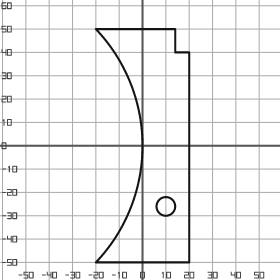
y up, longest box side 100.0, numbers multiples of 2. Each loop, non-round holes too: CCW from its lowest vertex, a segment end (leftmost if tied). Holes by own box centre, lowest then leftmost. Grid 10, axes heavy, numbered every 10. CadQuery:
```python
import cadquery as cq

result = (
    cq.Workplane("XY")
    .moveTo(-20.0, -50.0)
    .lineTo(20.0, -50.0)
    .lineTo(20.0, 40.0)
    .lineTo(14.0, 40.0)
    .lineTo(14.0, 50.0)
    .lineTo(-20.0, 50.0)
    .threePointArc((0.0, 0.0), (-20.0, -50.0))
    .close()
    .moveTo(10.0, -26.0)
    .circle(4.0)
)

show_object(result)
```